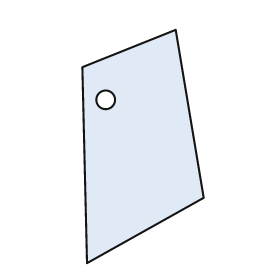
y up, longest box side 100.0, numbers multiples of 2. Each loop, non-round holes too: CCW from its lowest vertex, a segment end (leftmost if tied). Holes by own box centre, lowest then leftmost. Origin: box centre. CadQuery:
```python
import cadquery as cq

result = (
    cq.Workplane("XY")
    .moveTo(-24.0, -50.0)
    .lineTo(26.0, -22.0)
    .lineTo(14.0, 50.0)
    .lineTo(-26.0, 34.0)
    .close()
    .moveTo(-16.0, 20.0)
    .circle(4.0)
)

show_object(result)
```